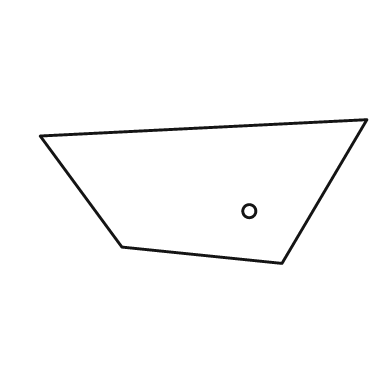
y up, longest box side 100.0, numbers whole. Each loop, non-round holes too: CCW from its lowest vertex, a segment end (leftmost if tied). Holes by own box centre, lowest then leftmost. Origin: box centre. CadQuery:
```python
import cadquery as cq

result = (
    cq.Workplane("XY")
    .moveTo(24.0, -22.0)
    .lineTo(50.0, 22.0)
    .lineTo(-50.0, 17.0)
    .lineTo(-25.0, -17.0)
    .close()
    .moveTo(14.0, -6.0)
    .circle(2.0)
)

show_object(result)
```